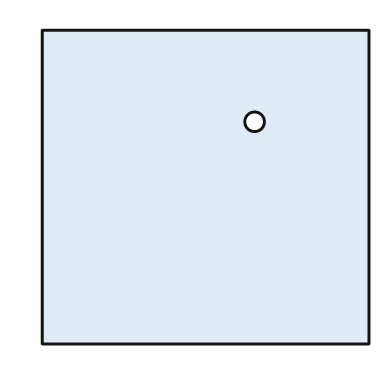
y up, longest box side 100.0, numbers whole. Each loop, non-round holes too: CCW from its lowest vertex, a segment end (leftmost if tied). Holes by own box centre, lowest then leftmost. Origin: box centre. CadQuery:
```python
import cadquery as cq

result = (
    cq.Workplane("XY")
    .moveTo(-50.0, -48.0)
    .lineTo(50.0, -48.0)
    .lineTo(50.0, 48.0)
    .lineTo(-50.0, 48.0)
    .close()
    .moveTo(15.0, 20.0)
    .circle(3.0)
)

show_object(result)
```